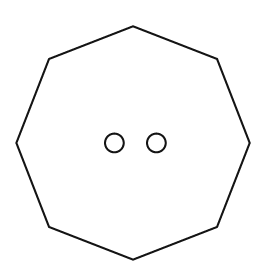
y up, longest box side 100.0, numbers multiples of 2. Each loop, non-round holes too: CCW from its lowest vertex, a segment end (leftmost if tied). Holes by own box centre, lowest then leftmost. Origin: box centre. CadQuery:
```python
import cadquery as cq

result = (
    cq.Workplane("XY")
    .moveTo(0.0, -50.0)
    .lineTo(36.0, -36.0)
    .lineTo(50.0, 0.0)
    .lineTo(36.0, 36.0)
    .lineTo(0.0, 50.0)
    .lineTo(-36.0, 36.0)
    .lineTo(-50.0, 0.0)
    .lineTo(-36.0, -36.0)
    .close()
    .moveTo(-8.0, 0.0)
    .circle(4.0)
    .moveTo(10.0, 0.0)
    .circle(4.0)
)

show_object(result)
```